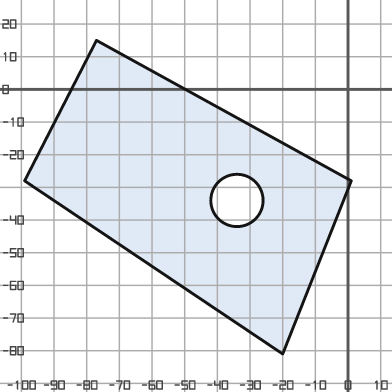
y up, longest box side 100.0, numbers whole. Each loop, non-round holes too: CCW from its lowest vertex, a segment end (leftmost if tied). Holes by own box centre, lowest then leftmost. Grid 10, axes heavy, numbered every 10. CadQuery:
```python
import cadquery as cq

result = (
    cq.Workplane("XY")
    .moveTo(-20.0, -81.0)
    .lineTo(1.0, -28.0)
    .lineTo(-77.0, 15.0)
    .lineTo(-99.0, -28.0)
    .close()
    .moveTo(-34.0, -34.0)
    .circle(8.0)
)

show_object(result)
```